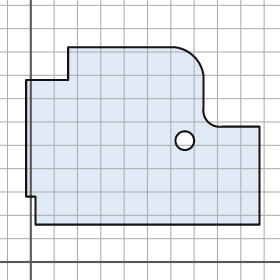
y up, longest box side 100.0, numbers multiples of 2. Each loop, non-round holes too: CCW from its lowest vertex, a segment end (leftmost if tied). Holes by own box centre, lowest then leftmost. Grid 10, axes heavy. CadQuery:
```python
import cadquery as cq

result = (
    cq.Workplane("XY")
    .moveTo(2.0, 16.0)
    .lineTo(98.0, 16.0)
    .lineTo(98.0, 58.0)
    .lineTo(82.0, 58.0)
    .threePointArc((76.0, 60.0), (74.0, 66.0))
    .lineTo(74.0, 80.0)
    .threePointArc((70.0, 88.0), (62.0, 92.0))
    .lineTo(16.0, 92.0)
    .lineTo(16.0, 78.0)
    .lineTo(-2.0, 78.0)
    .lineTo(-2.0, 28.0)
    .lineTo(2.0, 28.0)
    .close()
    .moveTo(66.0, 52.0)
    .circle(4.0)
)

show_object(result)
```